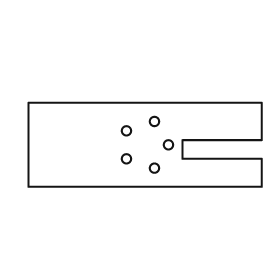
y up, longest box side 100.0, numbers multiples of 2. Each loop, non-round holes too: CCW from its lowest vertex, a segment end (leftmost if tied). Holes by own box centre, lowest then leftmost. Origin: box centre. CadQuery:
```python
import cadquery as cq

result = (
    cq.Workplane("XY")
    .moveTo(-50.0, -18.0)
    .lineTo(50.0, -18.0)
    .lineTo(50.0, -6.0)
    .lineTo(16.0, -6.0)
    .lineTo(16.0, 2.0)
    .lineTo(50.0, 2.0)
    .lineTo(50.0, 18.0)
    .lineTo(-50.0, 18.0)
    .close()
    .moveTo(4.0, -10.0)
    .circle(2.0)
    .moveTo(-8.0, -6.0)
    .circle(2.0)
    .moveTo(10.0, 0.0)
    .circle(2.0)
    .moveTo(-8.0, 6.0)
    .circle(2.0)
    .moveTo(4.0, 10.0)
    .circle(2.0)
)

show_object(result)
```